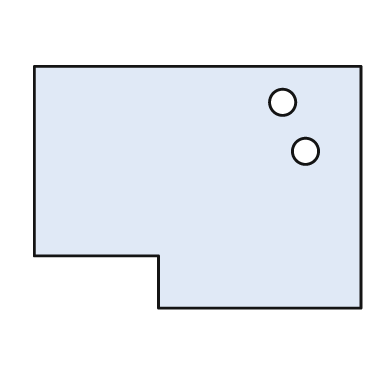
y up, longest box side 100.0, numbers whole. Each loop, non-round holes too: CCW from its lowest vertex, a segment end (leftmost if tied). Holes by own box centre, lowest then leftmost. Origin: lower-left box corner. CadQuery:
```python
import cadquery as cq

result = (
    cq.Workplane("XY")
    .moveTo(38.0, 0.0)
    .lineTo(100.0, 0.0)
    .lineTo(100.0, 74.0)
    .lineTo(0.0, 74.0)
    .lineTo(0.0, 16.0)
    .lineTo(38.0, 16.0)
    .close()
    .moveTo(83.0, 48.0)
    .circle(4.0)
    .moveTo(76.0, 63.0)
    .circle(4.0)
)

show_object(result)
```